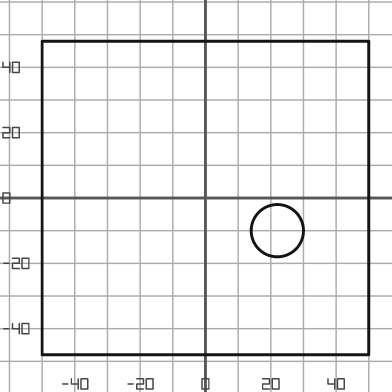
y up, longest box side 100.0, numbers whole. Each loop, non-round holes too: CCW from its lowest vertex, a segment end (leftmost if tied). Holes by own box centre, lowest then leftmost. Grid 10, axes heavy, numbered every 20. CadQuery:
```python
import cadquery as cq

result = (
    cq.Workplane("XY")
    .moveTo(-50.0, -48.0)
    .lineTo(50.0, -48.0)
    .lineTo(50.0, 48.0)
    .lineTo(-50.0, 48.0)
    .close()
    .moveTo(22.0, -10.0)
    .circle(8.0)
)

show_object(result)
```